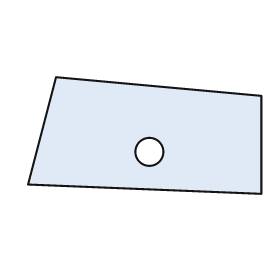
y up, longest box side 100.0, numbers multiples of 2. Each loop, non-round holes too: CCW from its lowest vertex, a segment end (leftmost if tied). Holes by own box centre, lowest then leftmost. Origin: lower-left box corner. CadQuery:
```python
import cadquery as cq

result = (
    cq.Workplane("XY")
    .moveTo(100.0, 0.0)
    .lineTo(100.0, 42.0)
    .lineTo(12.0, 50.0)
    .lineTo(0.0, 4.0)
    .close()
    .moveTo(52.0, 18.0)
    .circle(6.0)
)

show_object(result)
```